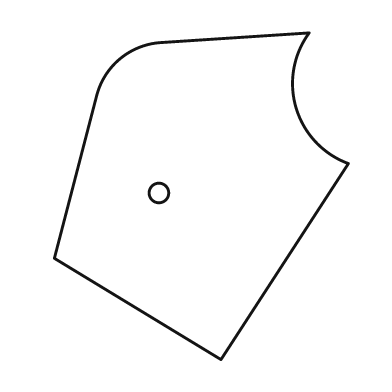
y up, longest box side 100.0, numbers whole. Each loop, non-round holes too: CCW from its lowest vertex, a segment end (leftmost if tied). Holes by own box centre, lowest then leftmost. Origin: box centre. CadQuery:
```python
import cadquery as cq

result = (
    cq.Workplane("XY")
    .moveTo(6.0, -50.0)
    .lineTo(45.0, 10.0)
    .threePointArc((29.0, 27.0), (33.0, 50.0))
    .lineTo(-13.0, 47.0)
    .threePointArc((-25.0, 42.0), (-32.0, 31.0))
    .lineTo(-45.0, -19.0)
    .close()
    .moveTo(-13.0, 1.0)
    .circle(3.0)
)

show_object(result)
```